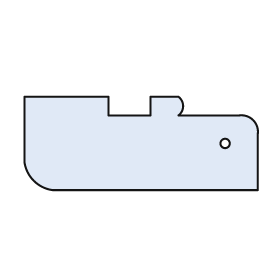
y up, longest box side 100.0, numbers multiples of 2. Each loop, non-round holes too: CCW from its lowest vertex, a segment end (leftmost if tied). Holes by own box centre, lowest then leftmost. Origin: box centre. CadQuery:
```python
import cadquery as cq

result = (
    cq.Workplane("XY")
    .moveTo(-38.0, -20.0)
    .lineTo(50.0, -20.0)
    .lineTo(50.0, 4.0)
    .threePointArc((48.0, 10.0), (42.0, 12.0))
    .lineTo(16.0, 12.0)
    .threePointArc((18.0, 16.0), (16.0, 20.0))
    .lineTo(4.0, 20.0)
    .lineTo(4.0, 12.0)
    .lineTo(-14.0, 12.0)
    .lineTo(-14.0, 20.0)
    .lineTo(-50.0, 20.0)
    .lineTo(-50.0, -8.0)
    .threePointArc((-46.0, -16.0), (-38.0, -20.0))
    .close()
    .moveTo(36.0, 0.0)
    .circle(2.0)
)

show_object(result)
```